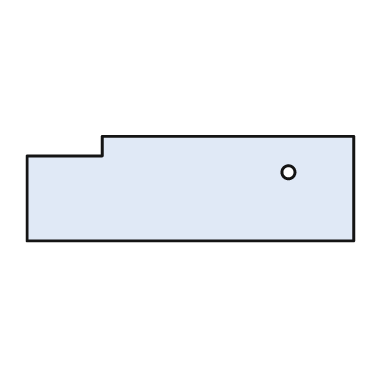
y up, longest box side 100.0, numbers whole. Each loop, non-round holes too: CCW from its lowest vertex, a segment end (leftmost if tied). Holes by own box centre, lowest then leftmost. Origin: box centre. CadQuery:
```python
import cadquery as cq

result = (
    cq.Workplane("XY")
    .moveTo(-50.0, -16.0)
    .lineTo(50.0, -16.0)
    .lineTo(50.0, 16.0)
    .lineTo(-27.0, 16.0)
    .lineTo(-27.0, 10.0)
    .lineTo(-50.0, 10.0)
    .close()
    .moveTo(30.0, 5.0)
    .circle(2.0)
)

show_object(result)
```